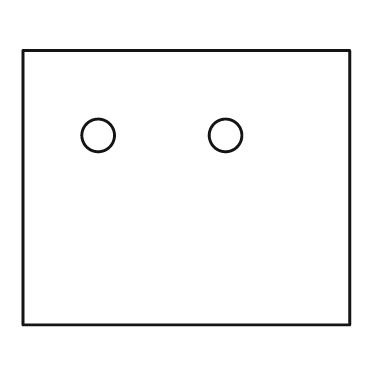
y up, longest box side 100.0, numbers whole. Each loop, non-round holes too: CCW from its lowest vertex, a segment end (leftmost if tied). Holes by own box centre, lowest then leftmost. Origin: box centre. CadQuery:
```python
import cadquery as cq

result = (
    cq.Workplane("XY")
    .moveTo(-50.0, -42.0)
    .lineTo(50.0, -42.0)
    .lineTo(50.0, 42.0)
    .lineTo(-50.0, 42.0)
    .close()
    .moveTo(-27.0, 16.0)
    .circle(5.0)
    .moveTo(12.0, 16.0)
    .circle(5.0)
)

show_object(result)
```